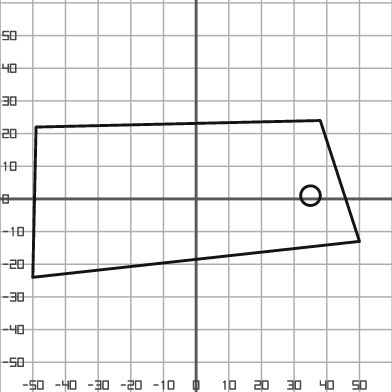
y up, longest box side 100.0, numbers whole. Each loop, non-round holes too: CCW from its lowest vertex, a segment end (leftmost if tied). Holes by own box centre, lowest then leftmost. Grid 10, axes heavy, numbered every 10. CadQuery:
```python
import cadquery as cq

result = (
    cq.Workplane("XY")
    .moveTo(-50.0, -24.0)
    .lineTo(50.0, -13.0)
    .lineTo(38.0, 24.0)
    .lineTo(-49.0, 22.0)
    .close()
    .moveTo(35.0, 1.0)
    .circle(3.0)
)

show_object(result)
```